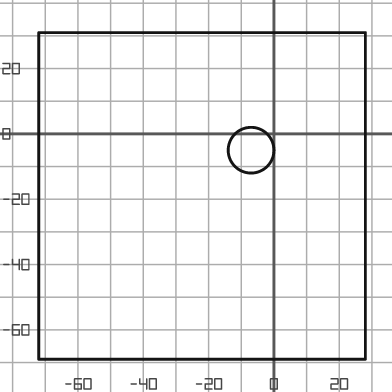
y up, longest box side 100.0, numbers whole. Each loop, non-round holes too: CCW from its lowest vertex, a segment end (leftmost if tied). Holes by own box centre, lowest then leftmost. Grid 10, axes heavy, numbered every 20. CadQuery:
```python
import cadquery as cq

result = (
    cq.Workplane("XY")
    .moveTo(-72.0, -69.0)
    .lineTo(28.0, -69.0)
    .lineTo(28.0, 31.0)
    .lineTo(-72.0, 31.0)
    .close()
    .moveTo(-7.0, -5.0)
    .circle(7.0)
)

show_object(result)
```